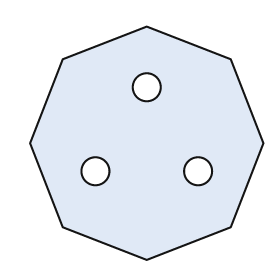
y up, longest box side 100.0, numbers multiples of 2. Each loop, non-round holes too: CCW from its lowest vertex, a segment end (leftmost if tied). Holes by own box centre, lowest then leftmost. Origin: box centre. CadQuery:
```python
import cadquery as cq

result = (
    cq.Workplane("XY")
    .moveTo(0.0, -50.0)
    .lineTo(36.0, -36.0)
    .lineTo(50.0, 0.0)
    .lineTo(36.0, 36.0)
    .lineTo(0.0, 50.0)
    .lineTo(-36.0, 36.0)
    .lineTo(-50.0, 0.0)
    .lineTo(-36.0, -36.0)
    .close()
    .moveTo(-22.0, -12.0)
    .circle(6.0)
    .moveTo(22.0, -12.0)
    .circle(6.0)
    .moveTo(0.0, 24.0)
    .circle(6.0)
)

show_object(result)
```